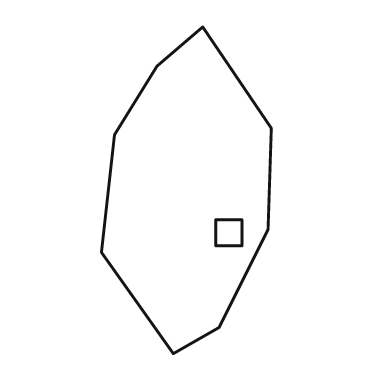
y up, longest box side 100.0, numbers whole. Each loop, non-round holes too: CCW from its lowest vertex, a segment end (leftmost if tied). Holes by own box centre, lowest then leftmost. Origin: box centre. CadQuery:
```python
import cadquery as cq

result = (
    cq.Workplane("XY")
    .moveTo(-4.0, -50.0)
    .lineTo(10.0, -42.0)
    .lineTo(25.0, -12.0)
    .lineTo(26.0, 19.0)
    .lineTo(5.0, 50.0)
    .lineTo(-9.0, 38.0)
    .lineTo(-22.0, 17.0)
    .lineTo(-26.0, -19.0)
    .close()
    .moveTo(9.0, -17.0)
    .lineTo(17.0, -17.0)
    .lineTo(17.0, -9.0)
    .lineTo(9.0, -9.0)
    .close()
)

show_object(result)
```